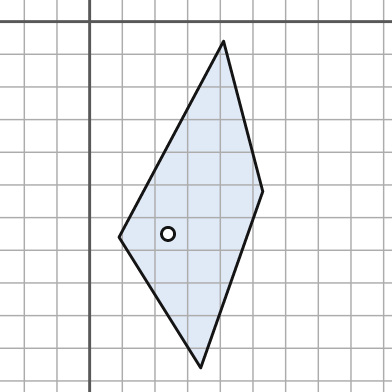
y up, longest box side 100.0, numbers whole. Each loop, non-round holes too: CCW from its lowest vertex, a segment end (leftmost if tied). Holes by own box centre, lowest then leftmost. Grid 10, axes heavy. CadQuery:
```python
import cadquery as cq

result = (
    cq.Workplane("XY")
    .moveTo(34.0, -106.0)
    .lineTo(53.0, -52.0)
    .lineTo(41.0, -6.0)
    .lineTo(9.0, -66.0)
    .close()
    .moveTo(24.0, -65.0)
    .circle(2.0)
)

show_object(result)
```